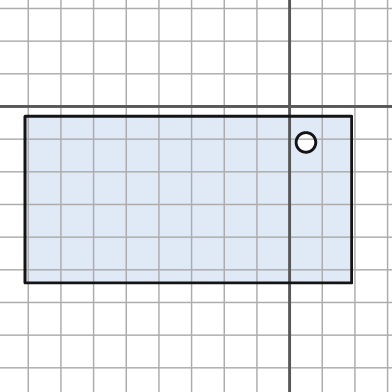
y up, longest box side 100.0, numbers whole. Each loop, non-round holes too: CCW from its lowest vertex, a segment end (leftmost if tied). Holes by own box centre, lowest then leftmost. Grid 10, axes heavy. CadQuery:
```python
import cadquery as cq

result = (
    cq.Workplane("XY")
    .moveTo(-81.0, -54.0)
    .lineTo(19.0, -54.0)
    .lineTo(19.0, -3.0)
    .lineTo(-81.0, -3.0)
    .close()
    .moveTo(5.0, -11.0)
    .circle(3.0)
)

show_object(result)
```